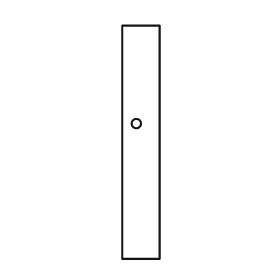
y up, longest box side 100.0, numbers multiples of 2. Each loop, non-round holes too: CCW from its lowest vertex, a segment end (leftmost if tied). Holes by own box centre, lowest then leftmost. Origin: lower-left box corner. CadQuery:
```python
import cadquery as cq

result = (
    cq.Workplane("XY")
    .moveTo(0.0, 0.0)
    .lineTo(16.0, 0.0)
    .lineTo(16.0, 100.0)
    .lineTo(0.0, 100.0)
    .close()
    .moveTo(6.0, 58.0)
    .circle(2.0)
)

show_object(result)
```